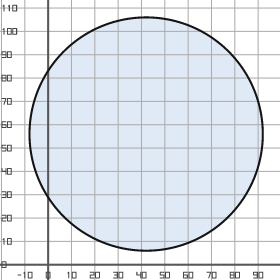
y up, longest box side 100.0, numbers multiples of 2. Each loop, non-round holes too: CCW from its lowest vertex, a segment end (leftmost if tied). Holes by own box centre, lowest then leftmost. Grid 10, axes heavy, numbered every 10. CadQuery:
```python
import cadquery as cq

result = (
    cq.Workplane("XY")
    .moveTo(42.0, 56.0)
    .circle(50.0)
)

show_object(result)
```